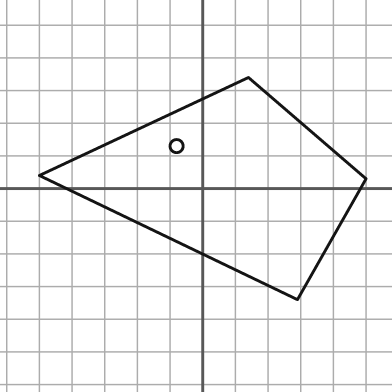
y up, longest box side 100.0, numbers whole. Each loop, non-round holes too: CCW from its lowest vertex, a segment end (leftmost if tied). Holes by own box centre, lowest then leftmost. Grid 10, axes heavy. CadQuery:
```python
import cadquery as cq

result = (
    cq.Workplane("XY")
    .moveTo(29.0, -34.0)
    .lineTo(50.0, 3.0)
    .lineTo(14.0, 34.0)
    .lineTo(-50.0, 4.0)
    .close()
    .moveTo(-8.0, 13.0)
    .circle(2.0)
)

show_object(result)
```